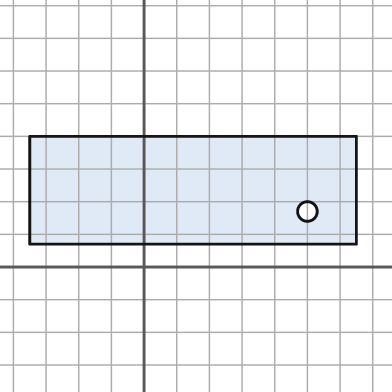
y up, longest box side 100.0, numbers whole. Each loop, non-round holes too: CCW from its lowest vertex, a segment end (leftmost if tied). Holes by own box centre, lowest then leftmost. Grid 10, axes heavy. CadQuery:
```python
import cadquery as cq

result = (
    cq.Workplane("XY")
    .moveTo(-35.0, 7.0)
    .lineTo(65.0, 7.0)
    .lineTo(65.0, 40.0)
    .lineTo(-35.0, 40.0)
    .close()
    .moveTo(50.0, 17.0)
    .circle(3.0)
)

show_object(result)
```